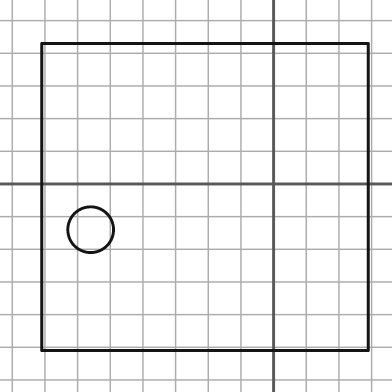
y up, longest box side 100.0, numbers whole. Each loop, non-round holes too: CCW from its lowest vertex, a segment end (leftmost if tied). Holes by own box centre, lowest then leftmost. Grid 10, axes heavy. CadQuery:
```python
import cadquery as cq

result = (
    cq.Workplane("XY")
    .moveTo(-71.0, -51.0)
    .lineTo(29.0, -51.0)
    .lineTo(29.0, 43.0)
    .lineTo(-71.0, 43.0)
    .close()
    .moveTo(-56.0, -14.0)
    .circle(7.0)
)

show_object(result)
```